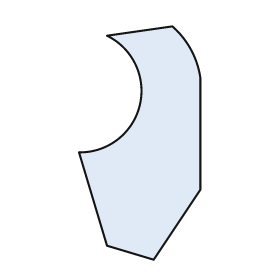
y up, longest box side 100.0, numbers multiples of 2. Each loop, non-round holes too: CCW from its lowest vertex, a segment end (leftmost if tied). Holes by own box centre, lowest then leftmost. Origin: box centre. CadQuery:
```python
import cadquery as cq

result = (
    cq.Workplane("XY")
    .moveTo(6.0, -50.0)
    .lineTo(26.0, -20.0)
    .lineTo(26.0, 28.0)
    .threePointArc((22.0, 40.0), (14.0, 50.0))
    .lineTo(-14.0, 46.0)
    .threePointArc((0.0, 16.0), (-26.0, -4.0))
    .lineTo(-14.0, -44.0)
    .close()
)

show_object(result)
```